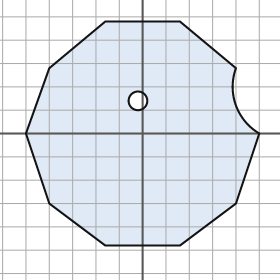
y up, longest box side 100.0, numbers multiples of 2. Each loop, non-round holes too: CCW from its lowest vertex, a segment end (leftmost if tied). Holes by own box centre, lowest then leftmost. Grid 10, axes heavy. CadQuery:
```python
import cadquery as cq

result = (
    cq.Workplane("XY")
    .moveTo(-16.0, -48.0)
    .lineTo(16.0, -48.0)
    .lineTo(40.0, -30.0)
    .lineTo(50.0, 0.0)
    .threePointArc((40.0, 12.0), (40.0, 28.0))
    .lineTo(16.0, 48.0)
    .lineTo(-16.0, 48.0)
    .lineTo(-40.0, 28.0)
    .lineTo(-50.0, 0.0)
    .lineTo(-40.0, -30.0)
    .close()
    .moveTo(-2.0, 14.0)
    .circle(4.0)
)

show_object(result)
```